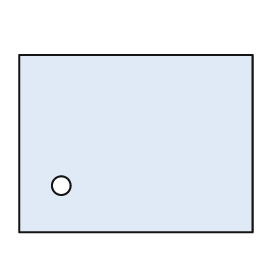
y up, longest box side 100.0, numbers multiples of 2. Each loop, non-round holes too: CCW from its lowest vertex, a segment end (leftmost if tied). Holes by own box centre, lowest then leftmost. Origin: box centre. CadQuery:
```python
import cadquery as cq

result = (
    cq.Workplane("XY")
    .moveTo(-50.0, -38.0)
    .lineTo(50.0, -38.0)
    .lineTo(50.0, 38.0)
    .lineTo(-50.0, 38.0)
    .close()
    .moveTo(-32.0, -18.0)
    .circle(4.0)
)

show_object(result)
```